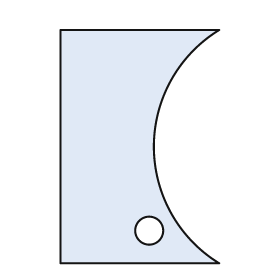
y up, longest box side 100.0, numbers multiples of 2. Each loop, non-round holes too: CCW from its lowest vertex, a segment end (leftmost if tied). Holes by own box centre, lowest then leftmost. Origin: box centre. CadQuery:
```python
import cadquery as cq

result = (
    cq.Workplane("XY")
    .moveTo(-34.0, -50.0)
    .lineTo(34.0, -50.0)
    .threePointArc((6.0, 0.0), (34.0, 50.0))
    .lineTo(-34.0, 50.0)
    .close()
    .moveTo(4.0, -36.0)
    .circle(6.0)
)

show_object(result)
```